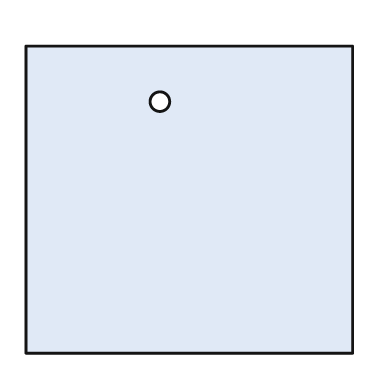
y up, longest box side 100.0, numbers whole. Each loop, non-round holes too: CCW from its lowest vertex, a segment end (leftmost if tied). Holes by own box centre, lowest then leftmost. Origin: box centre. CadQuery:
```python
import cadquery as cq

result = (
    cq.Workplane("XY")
    .moveTo(-50.0, -47.0)
    .lineTo(50.0, -47.0)
    .lineTo(50.0, 47.0)
    .lineTo(-50.0, 47.0)
    .close()
    .moveTo(-9.0, 30.0)
    .circle(3.0)
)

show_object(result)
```